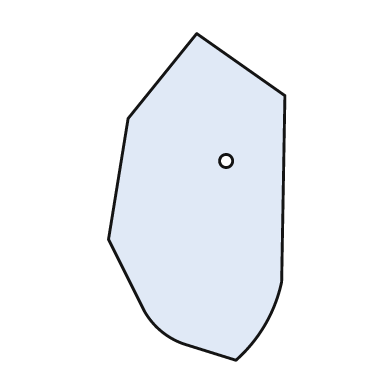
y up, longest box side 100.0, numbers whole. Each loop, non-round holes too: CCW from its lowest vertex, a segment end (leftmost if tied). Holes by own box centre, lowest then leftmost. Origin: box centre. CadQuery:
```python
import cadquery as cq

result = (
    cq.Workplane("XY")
    .moveTo(12.0, -50.0)
    .threePointArc((21.0, -39.0), (26.0, -26.0))
    .lineTo(27.0, 31.0)
    .lineTo(0.0, 50.0)
    .lineTo(-21.0, 24.0)
    .lineTo(-27.0, -13.0)
    .lineTo(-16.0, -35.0)
    .threePointArc((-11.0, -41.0), (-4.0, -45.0))
    .close()
    .moveTo(9.0, 11.0)
    .circle(2.0)
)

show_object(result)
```